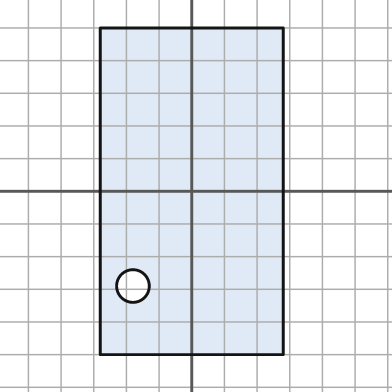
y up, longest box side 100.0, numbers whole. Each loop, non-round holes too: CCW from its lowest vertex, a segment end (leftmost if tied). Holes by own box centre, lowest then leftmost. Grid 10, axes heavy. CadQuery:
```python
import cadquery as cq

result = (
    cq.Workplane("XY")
    .moveTo(-28.0, -50.0)
    .lineTo(28.0, -50.0)
    .lineTo(28.0, 50.0)
    .lineTo(-28.0, 50.0)
    .close()
    .moveTo(-18.0, -29.0)
    .circle(5.0)
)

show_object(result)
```